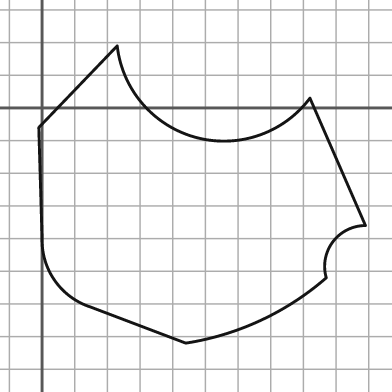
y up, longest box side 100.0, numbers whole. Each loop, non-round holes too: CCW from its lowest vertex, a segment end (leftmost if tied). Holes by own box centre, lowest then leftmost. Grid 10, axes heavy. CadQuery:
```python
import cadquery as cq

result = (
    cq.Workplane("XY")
    .moveTo(44.0, -72.0)
    .threePointArc((67.0, -65.0), (87.0, -52.0))
    .threePointArc((89.0, -41.0), (99.0, -36.0))
    .lineTo(82.0, 3.0)
    .threePointArc((47.0, -9.0), (23.0, 19.0))
    .lineTo(-1.0, -6.0)
    .lineTo(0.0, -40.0)
    .threePointArc((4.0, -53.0), (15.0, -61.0))
    .close()
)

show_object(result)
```